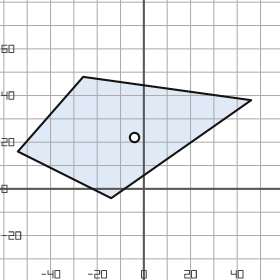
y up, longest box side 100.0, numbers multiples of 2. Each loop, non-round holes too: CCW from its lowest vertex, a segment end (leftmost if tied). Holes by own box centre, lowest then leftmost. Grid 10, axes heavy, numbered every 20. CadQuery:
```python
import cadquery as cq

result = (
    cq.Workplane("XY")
    .moveTo(-14.0, -4.0)
    .lineTo(46.0, 38.0)
    .lineTo(-26.0, 48.0)
    .lineTo(-54.0, 16.0)
    .close()
    .moveTo(-4.0, 22.0)
    .circle(2.0)
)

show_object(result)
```